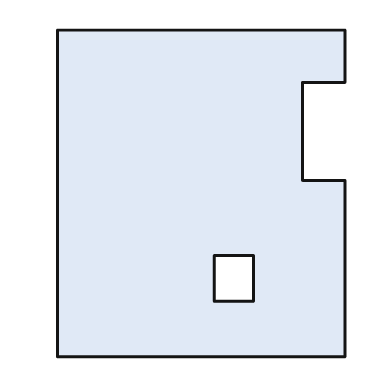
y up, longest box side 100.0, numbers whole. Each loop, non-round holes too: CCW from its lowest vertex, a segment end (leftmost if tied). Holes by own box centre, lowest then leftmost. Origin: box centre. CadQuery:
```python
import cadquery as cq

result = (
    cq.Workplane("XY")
    .moveTo(-44.0, -50.0)
    .lineTo(44.0, -50.0)
    .lineTo(44.0, 4.0)
    .lineTo(31.0, 4.0)
    .lineTo(31.0, 34.0)
    .lineTo(44.0, 34.0)
    .lineTo(44.0, 50.0)
    .lineTo(-44.0, 50.0)
    .close()
    .moveTo(4.0, -33.0)
    .lineTo(16.0, -33.0)
    .lineTo(16.0, -19.0)
    .lineTo(4.0, -19.0)
    .close()
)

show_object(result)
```